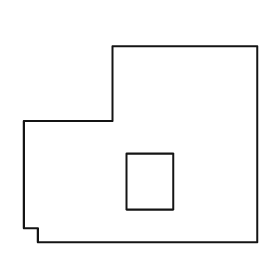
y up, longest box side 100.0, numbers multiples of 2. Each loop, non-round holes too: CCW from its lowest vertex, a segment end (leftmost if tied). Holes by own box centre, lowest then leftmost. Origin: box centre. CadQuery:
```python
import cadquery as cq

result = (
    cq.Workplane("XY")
    .moveTo(-44.0, -42.0)
    .lineTo(50.0, -42.0)
    .lineTo(50.0, 42.0)
    .lineTo(-12.0, 42.0)
    .lineTo(-12.0, 10.0)
    .lineTo(-50.0, 10.0)
    .lineTo(-50.0, -36.0)
    .lineTo(-44.0, -36.0)
    .close()
    .moveTo(-6.0, -28.0)
    .lineTo(14.0, -28.0)
    .lineTo(14.0, -4.0)
    .lineTo(-6.0, -4.0)
    .close()
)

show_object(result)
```